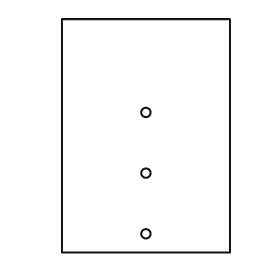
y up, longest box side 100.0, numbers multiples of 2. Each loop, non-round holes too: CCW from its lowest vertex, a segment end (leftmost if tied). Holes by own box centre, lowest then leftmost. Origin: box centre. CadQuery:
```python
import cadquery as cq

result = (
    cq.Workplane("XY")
    .moveTo(-36.0, -50.0)
    .lineTo(36.0, -50.0)
    .lineTo(36.0, 50.0)
    .lineTo(-36.0, 50.0)
    .close()
    .moveTo(0.0, -42.0)
    .circle(2.0)
    .moveTo(0.0, -16.0)
    .circle(2.0)
    .moveTo(0.0, 10.0)
    .circle(2.0)
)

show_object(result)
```